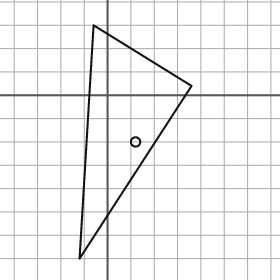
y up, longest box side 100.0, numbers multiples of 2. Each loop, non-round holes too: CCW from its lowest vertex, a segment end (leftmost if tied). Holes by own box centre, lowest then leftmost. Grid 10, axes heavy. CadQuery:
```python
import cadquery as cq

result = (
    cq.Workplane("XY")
    .moveTo(-12.0, -70.0)
    .lineTo(36.0, 4.0)
    .lineTo(-6.0, 30.0)
    .close()
    .moveTo(12.0, -20.0)
    .circle(2.0)
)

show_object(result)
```